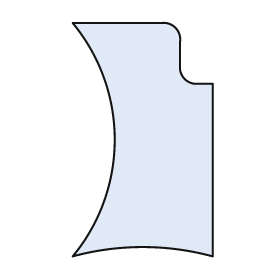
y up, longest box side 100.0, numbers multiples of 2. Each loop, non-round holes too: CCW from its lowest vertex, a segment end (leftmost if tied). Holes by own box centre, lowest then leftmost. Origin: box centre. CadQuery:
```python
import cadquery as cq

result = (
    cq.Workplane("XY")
    .moveTo(-30.0, -50.0)
    .threePointArc((0.0, -46.0), (30.0, -50.0))
    .lineTo(30.0, 24.0)
    .lineTo(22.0, 24.0)
    .threePointArc((18.0, 26.0), (16.0, 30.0))
    .lineTo(16.0, 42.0)
    .threePointArc((14.0, 48.0), (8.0, 50.0))
    .lineTo(-30.0, 50.0)
    .threePointArc((-12.0, 0.0), (-30.0, -50.0))
    .close()
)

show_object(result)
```